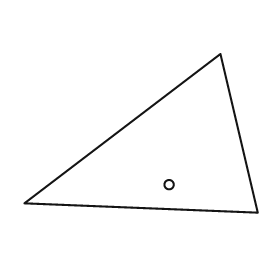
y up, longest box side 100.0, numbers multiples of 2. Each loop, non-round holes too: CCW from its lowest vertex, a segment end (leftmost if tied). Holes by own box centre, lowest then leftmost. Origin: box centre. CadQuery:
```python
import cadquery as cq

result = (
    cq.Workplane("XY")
    .moveTo(50.0, -34.0)
    .lineTo(34.0, 34.0)
    .lineTo(-50.0, -30.0)
    .close()
    .moveTo(12.0, -22.0)
    .circle(2.0)
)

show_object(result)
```